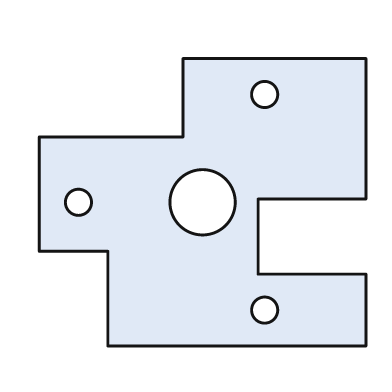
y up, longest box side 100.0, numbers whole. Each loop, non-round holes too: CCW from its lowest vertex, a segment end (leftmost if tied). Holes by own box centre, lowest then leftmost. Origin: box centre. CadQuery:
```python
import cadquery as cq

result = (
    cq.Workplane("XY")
    .moveTo(-29.0, -44.0)
    .lineTo(50.0, -44.0)
    .lineTo(50.0, -22.0)
    .lineTo(17.0, -22.0)
    .lineTo(17.0, 1.0)
    .lineTo(50.0, 1.0)
    .lineTo(50.0, 44.0)
    .lineTo(-6.0, 44.0)
    .lineTo(-6.0, 20.0)
    .lineTo(-50.0, 20.0)
    .lineTo(-50.0, -15.0)
    .lineTo(-29.0, -15.0)
    .close()
    .moveTo(19.0, -33.0)
    .circle(4.0)
    .moveTo(-38.0, 0.0)
    .circle(4.0)
    .moveTo(0.0, 0.0)
    .circle(10.0)
    .moveTo(19.0, 33.0)
    .circle(4.0)
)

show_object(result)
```